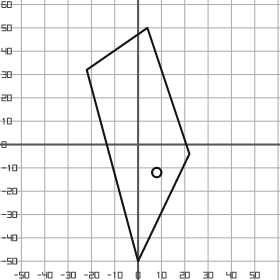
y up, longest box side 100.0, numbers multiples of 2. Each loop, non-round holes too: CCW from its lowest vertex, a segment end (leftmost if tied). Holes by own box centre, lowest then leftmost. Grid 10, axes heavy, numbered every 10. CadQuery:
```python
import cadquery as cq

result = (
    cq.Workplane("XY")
    .moveTo(0.0, -50.0)
    .lineTo(22.0, -4.0)
    .lineTo(4.0, 50.0)
    .lineTo(-22.0, 32.0)
    .close()
    .moveTo(8.0, -12.0)
    .circle(2.0)
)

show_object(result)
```